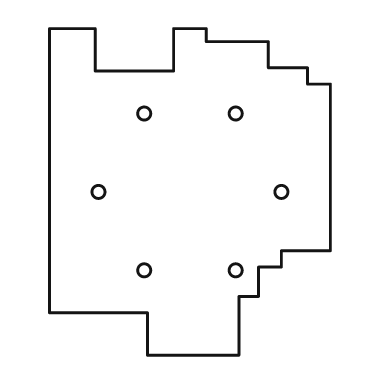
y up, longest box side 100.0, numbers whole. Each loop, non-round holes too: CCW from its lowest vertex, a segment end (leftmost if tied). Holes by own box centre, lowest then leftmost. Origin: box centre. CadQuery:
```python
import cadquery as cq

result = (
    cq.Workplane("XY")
    .moveTo(-13.0, -50.0)
    .lineTo(15.0, -50.0)
    .lineTo(15.0, -32.0)
    .lineTo(21.0, -32.0)
    .lineTo(21.0, -23.0)
    .lineTo(28.0, -23.0)
    .lineTo(28.0, -18.0)
    .lineTo(43.0, -18.0)
    .lineTo(43.0, 33.0)
    .lineTo(36.0, 33.0)
    .lineTo(36.0, 38.0)
    .lineTo(24.0, 38.0)
    .lineTo(24.0, 46.0)
    .lineTo(5.0, 46.0)
    .lineTo(5.0, 50.0)
    .lineTo(-5.0, 50.0)
    .lineTo(-5.0, 37.0)
    .lineTo(-29.0, 37.0)
    .lineTo(-29.0, 50.0)
    .lineTo(-43.0, 50.0)
    .lineTo(-43.0, -37.0)
    .lineTo(-13.0, -37.0)
    .close()
    .moveTo(-14.0, -24.0)
    .circle(2.0)
    .moveTo(14.0, -24.0)
    .circle(2.0)
    .moveTo(-28.0, 0.0)
    .circle(2.0)
    .moveTo(28.0, 0.0)
    .circle(2.0)
    .moveTo(-14.0, 24.0)
    .circle(2.0)
    .moveTo(14.0, 24.0)
    .circle(2.0)
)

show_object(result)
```